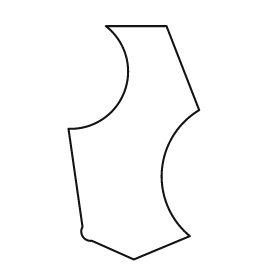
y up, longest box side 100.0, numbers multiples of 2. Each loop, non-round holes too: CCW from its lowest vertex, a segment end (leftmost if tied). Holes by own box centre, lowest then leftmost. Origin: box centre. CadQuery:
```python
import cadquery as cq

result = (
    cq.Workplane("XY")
    .moveTo(0.0, -50.0)
    .lineTo(24.0, -40.0)
    .threePointArc((12.0, -12.0), (28.0, 14.0))
    .lineTo(14.0, 50.0)
    .lineTo(-12.0, 50.0)
    .threePointArc((-4.0, 22.0), (-28.0, 6.0))
    .lineTo(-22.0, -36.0)
    .threePointArc((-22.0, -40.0), (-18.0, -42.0))
    .close()
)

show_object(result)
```